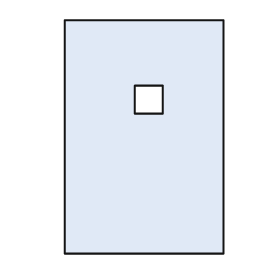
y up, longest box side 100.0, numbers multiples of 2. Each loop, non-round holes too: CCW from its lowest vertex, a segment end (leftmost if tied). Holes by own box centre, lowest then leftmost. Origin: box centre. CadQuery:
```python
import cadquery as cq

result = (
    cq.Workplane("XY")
    .moveTo(-34.0, -50.0)
    .lineTo(34.0, -50.0)
    .lineTo(34.0, 50.0)
    .lineTo(-34.0, 50.0)
    .close()
    .moveTo(-4.0, 10.0)
    .lineTo(8.0, 10.0)
    .lineTo(8.0, 22.0)
    .lineTo(-4.0, 22.0)
    .close()
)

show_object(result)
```